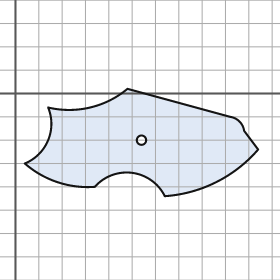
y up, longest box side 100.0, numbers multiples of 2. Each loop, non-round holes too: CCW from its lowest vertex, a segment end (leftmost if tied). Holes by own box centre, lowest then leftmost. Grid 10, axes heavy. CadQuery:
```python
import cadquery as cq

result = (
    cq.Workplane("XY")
    .moveTo(64.0, -44.0)
    .threePointArc((86.0, -38.0), (104.0, -24.0))
    .lineTo(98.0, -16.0)
    .threePointArc((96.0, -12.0), (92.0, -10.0))
    .lineTo(48.0, 2.0)
    .threePointArc((32.0, -6.0), (14.0, -6.0))
    .threePointArc((14.0, -20.0), (4.0, -30.0))
    .threePointArc((18.0, -38.0), (34.0, -40.0))
    .threePointArc((50.0, -34.0), (64.0, -44.0))
    .close()
    .moveTo(54.0, -20.0)
    .circle(2.0)
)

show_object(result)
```